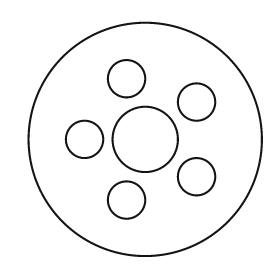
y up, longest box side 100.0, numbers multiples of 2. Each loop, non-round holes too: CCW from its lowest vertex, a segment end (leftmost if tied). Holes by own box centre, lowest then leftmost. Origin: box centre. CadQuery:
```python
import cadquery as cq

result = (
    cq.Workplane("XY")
    .moveTo(0.0, 0.0)
    .circle(50.0)
    .moveTo(-8.0, -26.0)
    .circle(8.0)
    .moveTo(22.0, -16.0)
    .circle(8.0)
    .moveTo(-26.0, 0.0)
    .circle(8.0)
    .moveTo(0.0, 0.0)
    .circle(14.0)
    .moveTo(22.0, 16.0)
    .circle(8.0)
    .moveTo(-8.0, 26.0)
    .circle(8.0)
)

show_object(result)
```